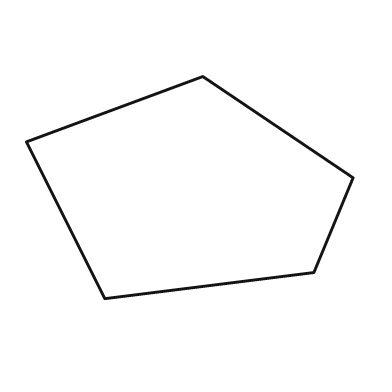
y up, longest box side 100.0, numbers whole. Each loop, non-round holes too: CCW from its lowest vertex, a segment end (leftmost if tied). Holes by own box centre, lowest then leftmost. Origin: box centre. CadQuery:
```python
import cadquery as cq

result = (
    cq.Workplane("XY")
    .moveTo(-26.0, -34.0)
    .lineTo(38.0, -26.0)
    .lineTo(50.0, 3.0)
    .lineTo(4.0, 34.0)
    .lineTo(-50.0, 14.0)
    .close()
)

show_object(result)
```